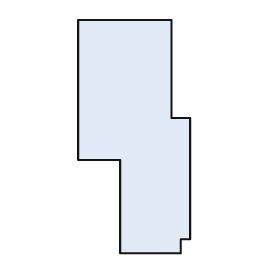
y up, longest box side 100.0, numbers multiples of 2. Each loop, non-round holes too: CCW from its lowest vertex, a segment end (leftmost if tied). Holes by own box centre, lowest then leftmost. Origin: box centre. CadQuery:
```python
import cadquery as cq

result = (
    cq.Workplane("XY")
    .moveTo(-6.0, -50.0)
    .lineTo(20.0, -50.0)
    .lineTo(20.0, -44.0)
    .lineTo(24.0, -44.0)
    .lineTo(24.0, 8.0)
    .lineTo(16.0, 8.0)
    .lineTo(16.0, 50.0)
    .lineTo(-24.0, 50.0)
    .lineTo(-24.0, -10.0)
    .lineTo(-6.0, -10.0)
    .close()
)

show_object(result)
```